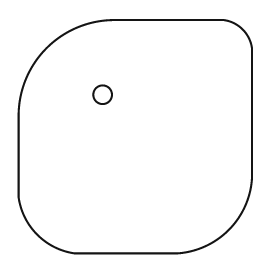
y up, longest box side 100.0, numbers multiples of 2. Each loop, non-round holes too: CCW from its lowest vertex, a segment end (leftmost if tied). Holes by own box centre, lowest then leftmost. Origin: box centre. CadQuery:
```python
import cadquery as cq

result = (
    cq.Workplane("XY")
    .moveTo(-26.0, -50.0)
    .lineTo(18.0, -50.0)
    .threePointArc((40.0, -40.0), (50.0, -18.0))
    .lineTo(50.0, 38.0)
    .threePointArc((46.0, 46.0), (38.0, 50.0))
    .lineTo(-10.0, 50.0)
    .threePointArc((-38.0, 38.0), (-50.0, 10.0))
    .lineTo(-50.0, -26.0)
    .threePointArc((-42.0, -42.0), (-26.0, -50.0))
    .close()
    .moveTo(-14.0, 18.0)
    .circle(4.0)
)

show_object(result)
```